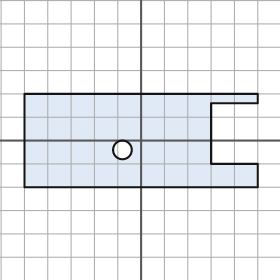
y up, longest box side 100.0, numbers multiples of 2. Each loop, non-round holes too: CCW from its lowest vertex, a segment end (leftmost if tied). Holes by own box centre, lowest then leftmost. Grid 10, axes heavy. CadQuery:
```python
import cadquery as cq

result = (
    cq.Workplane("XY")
    .moveTo(-50.0, -20.0)
    .lineTo(50.0, -20.0)
    .lineTo(50.0, -10.0)
    .lineTo(30.0, -10.0)
    .lineTo(30.0, 16.0)
    .lineTo(50.0, 16.0)
    .lineTo(50.0, 20.0)
    .lineTo(-50.0, 20.0)
    .close()
    .moveTo(-8.0, -4.0)
    .circle(4.0)
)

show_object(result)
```